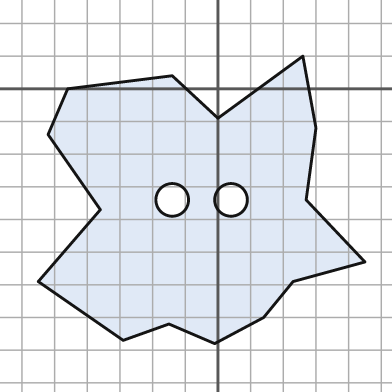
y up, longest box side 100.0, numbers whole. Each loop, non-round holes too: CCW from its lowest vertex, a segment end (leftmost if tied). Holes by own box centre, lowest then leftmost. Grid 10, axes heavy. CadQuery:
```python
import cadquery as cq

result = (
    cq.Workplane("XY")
    .moveTo(-1.0, -78.0)
    .lineTo(14.0, -70.0)
    .lineTo(23.0, -59.0)
    .lineTo(45.0, -53.0)
    .lineTo(27.0, -34.0)
    .lineTo(30.0, -12.0)
    .lineTo(26.0, 10.0)
    .lineTo(0.0, -9.0)
    .lineTo(-14.0, 4.0)
    .lineTo(-46.0, 0.0)
    .lineTo(-52.0, -14.0)
    .lineTo(-36.0, -37.0)
    .lineTo(-55.0, -59.0)
    .lineTo(-29.0, -77.0)
    .lineTo(-15.0, -72.0)
    .close()
    .moveTo(-14.0, -34.0)
    .circle(5.0)
    .moveTo(4.0, -34.0)
    .circle(5.0)
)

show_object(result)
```